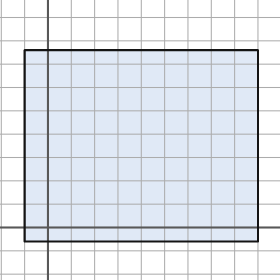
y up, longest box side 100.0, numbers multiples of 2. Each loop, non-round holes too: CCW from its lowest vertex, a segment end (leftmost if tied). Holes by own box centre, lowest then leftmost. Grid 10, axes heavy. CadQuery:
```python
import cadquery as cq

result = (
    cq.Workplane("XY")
    .moveTo(-10.0, -6.0)
    .lineTo(90.0, -6.0)
    .lineTo(90.0, 76.0)
    .lineTo(-10.0, 76.0)
    .close()
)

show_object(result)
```